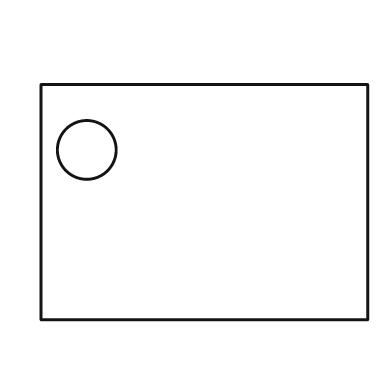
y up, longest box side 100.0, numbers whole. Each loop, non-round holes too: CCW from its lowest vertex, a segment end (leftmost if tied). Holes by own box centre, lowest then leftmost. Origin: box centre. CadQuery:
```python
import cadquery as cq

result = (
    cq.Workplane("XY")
    .moveTo(-50.0, -36.0)
    .lineTo(50.0, -36.0)
    .lineTo(50.0, 36.0)
    .lineTo(-50.0, 36.0)
    .close()
    .moveTo(-36.0, 16.0)
    .circle(9.0)
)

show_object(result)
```